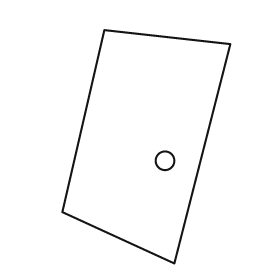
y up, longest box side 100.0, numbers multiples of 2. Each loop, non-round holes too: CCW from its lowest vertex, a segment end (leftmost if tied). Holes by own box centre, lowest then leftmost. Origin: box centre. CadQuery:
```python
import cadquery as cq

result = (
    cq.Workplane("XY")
    .moveTo(12.0, -50.0)
    .lineTo(36.0, 44.0)
    .lineTo(-18.0, 50.0)
    .lineTo(-36.0, -28.0)
    .close()
    .moveTo(8.0, -6.0)
    .circle(4.0)
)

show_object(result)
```